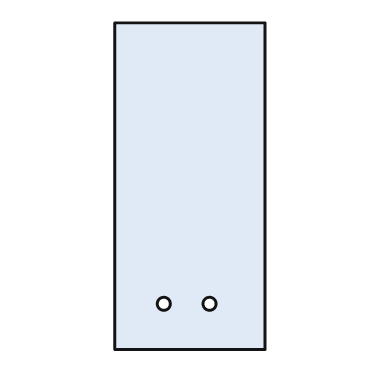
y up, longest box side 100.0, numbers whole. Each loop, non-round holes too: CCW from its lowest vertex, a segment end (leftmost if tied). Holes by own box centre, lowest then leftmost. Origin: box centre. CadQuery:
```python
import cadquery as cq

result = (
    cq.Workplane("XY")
    .moveTo(-23.0, -50.0)
    .lineTo(23.0, -50.0)
    .lineTo(23.0, 50.0)
    .lineTo(-23.0, 50.0)
    .close()
    .moveTo(-8.0, -36.0)
    .circle(2.0)
    .moveTo(6.0, -36.0)
    .circle(2.0)
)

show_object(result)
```